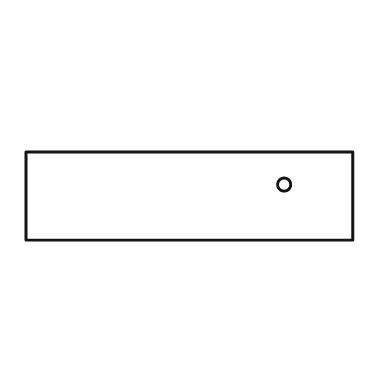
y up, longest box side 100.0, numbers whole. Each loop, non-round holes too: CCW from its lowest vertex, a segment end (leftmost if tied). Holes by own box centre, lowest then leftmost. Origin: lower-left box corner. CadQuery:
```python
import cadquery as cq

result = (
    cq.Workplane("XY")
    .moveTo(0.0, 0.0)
    .lineTo(100.0, 0.0)
    .lineTo(100.0, 27.0)
    .lineTo(0.0, 27.0)
    .close()
    .moveTo(79.0, 17.0)
    .circle(2.0)
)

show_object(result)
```